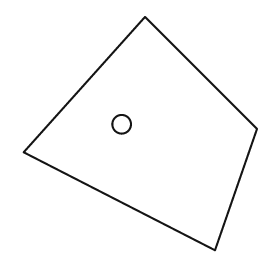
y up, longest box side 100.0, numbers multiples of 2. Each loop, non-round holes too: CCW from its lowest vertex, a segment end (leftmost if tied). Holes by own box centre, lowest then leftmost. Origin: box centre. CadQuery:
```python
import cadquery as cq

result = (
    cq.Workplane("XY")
    .moveTo(32.0, -50.0)
    .lineTo(50.0, 2.0)
    .lineTo(2.0, 50.0)
    .lineTo(-50.0, -8.0)
    .close()
    .moveTo(-8.0, 4.0)
    .circle(4.0)
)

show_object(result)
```